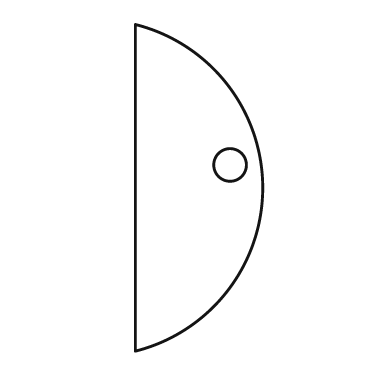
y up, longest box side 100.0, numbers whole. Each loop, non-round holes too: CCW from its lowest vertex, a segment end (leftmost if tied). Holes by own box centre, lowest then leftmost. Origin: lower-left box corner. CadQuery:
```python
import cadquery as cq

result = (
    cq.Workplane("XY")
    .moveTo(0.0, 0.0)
    .threePointArc((39.0, 50.0), (0.0, 100.0))
    .close()
    .moveTo(29.0, 57.0)
    .circle(5.0)
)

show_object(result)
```